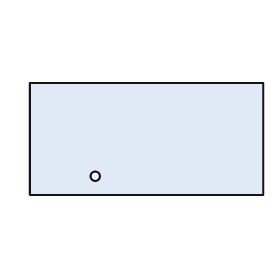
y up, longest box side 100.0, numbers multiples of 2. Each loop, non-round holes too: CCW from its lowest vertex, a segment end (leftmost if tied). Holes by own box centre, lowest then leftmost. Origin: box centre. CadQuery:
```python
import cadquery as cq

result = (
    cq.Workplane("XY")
    .moveTo(-50.0, -24.0)
    .lineTo(50.0, -24.0)
    .lineTo(50.0, 24.0)
    .lineTo(-50.0, 24.0)
    .close()
    .moveTo(-22.0, -16.0)
    .circle(2.0)
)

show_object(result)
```